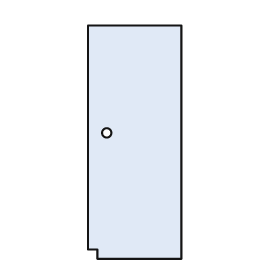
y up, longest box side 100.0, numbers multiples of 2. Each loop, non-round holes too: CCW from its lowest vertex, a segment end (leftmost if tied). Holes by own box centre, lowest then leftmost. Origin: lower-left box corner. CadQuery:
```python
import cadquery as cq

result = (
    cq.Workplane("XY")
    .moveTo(4.0, 0.0)
    .lineTo(40.0, 0.0)
    .lineTo(40.0, 100.0)
    .lineTo(0.0, 100.0)
    .lineTo(0.0, 4.0)
    .lineTo(4.0, 4.0)
    .close()
    .moveTo(8.0, 54.0)
    .circle(2.0)
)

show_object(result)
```